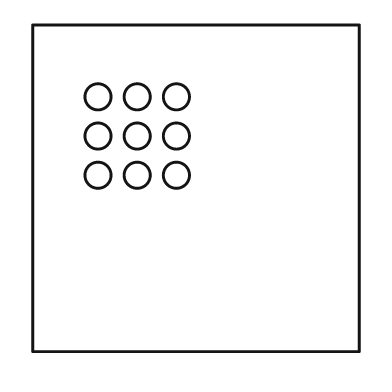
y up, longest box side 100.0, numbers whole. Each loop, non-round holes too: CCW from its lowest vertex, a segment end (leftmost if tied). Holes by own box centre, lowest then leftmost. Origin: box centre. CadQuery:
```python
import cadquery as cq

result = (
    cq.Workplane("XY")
    .moveTo(-50.0, -50.0)
    .lineTo(50.0, -50.0)
    .lineTo(50.0, 50.0)
    .lineTo(-50.0, 50.0)
    .close()
    .moveTo(-30.0, 4.0)
    .circle(4.0)
    .moveTo(-18.0, 4.0)
    .circle(4.0)
    .moveTo(-6.0, 4.0)
    .circle(4.0)
    .moveTo(-30.0, 16.0)
    .circle(4.0)
    .moveTo(-18.0, 16.0)
    .circle(4.0)
    .moveTo(-6.0, 16.0)
    .circle(4.0)
    .moveTo(-30.0, 28.0)
    .circle(4.0)
    .moveTo(-18.0, 28.0)
    .circle(4.0)
    .moveTo(-6.0, 28.0)
    .circle(4.0)
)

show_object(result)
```